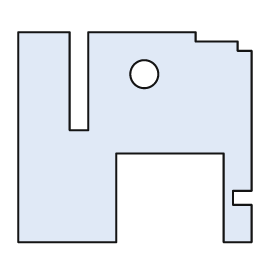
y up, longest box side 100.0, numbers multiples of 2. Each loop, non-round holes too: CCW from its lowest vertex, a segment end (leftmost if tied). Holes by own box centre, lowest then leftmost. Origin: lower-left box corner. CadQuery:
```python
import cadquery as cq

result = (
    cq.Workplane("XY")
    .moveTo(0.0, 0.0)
    .lineTo(42.0, 0.0)
    .lineTo(42.0, 38.0)
    .lineTo(88.0, 38.0)
    .lineTo(88.0, 0.0)
    .lineTo(100.0, 0.0)
    .lineTo(100.0, 16.0)
    .lineTo(92.0, 16.0)
    .lineTo(92.0, 22.0)
    .lineTo(100.0, 22.0)
    .lineTo(100.0, 82.0)
    .lineTo(94.0, 82.0)
    .lineTo(94.0, 86.0)
    .lineTo(76.0, 86.0)
    .lineTo(76.0, 90.0)
    .lineTo(30.0, 90.0)
    .lineTo(30.0, 48.0)
    .lineTo(22.0, 48.0)
    .lineTo(22.0, 90.0)
    .lineTo(0.0, 90.0)
    .close()
    .moveTo(54.0, 72.0)
    .circle(6.0)
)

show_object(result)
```